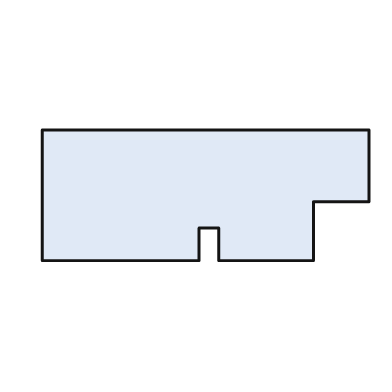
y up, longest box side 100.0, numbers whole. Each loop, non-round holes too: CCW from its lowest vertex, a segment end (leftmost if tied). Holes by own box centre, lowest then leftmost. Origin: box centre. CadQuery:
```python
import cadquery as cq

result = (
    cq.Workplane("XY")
    .moveTo(-50.0, -20.0)
    .lineTo(-2.0, -20.0)
    .lineTo(-2.0, -10.0)
    .lineTo(4.0, -10.0)
    .lineTo(4.0, -20.0)
    .lineTo(33.0, -20.0)
    .lineTo(33.0, -2.0)
    .lineTo(50.0, -2.0)
    .lineTo(50.0, 20.0)
    .lineTo(-50.0, 20.0)
    .close()
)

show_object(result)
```